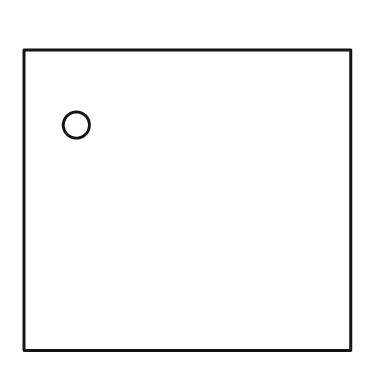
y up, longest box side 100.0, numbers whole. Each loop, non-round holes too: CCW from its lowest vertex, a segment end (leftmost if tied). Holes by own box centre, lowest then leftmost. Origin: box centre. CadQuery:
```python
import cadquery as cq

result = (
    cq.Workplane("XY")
    .moveTo(-50.0, -46.0)
    .lineTo(50.0, -46.0)
    .lineTo(50.0, 46.0)
    .lineTo(-50.0, 46.0)
    .close()
    .moveTo(-34.0, 23.0)
    .circle(4.0)
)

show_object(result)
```